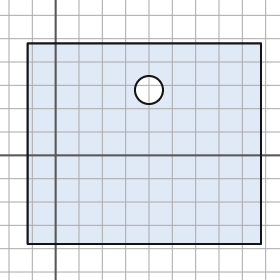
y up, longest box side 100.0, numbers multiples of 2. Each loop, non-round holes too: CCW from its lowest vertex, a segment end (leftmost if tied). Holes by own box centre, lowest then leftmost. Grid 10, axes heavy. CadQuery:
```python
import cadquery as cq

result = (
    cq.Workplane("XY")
    .moveTo(-12.0, -38.0)
    .lineTo(88.0, -38.0)
    .lineTo(88.0, 48.0)
    .lineTo(-12.0, 48.0)
    .close()
    .moveTo(40.0, 28.0)
    .circle(6.0)
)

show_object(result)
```